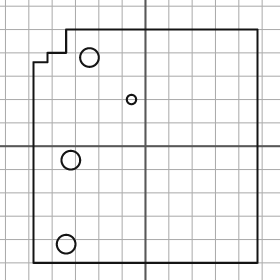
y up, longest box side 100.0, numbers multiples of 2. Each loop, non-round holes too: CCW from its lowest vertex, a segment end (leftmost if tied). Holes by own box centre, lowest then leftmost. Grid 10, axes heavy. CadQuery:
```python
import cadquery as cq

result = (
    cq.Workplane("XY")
    .moveTo(-48.0, -50.0)
    .lineTo(48.0, -50.0)
    .lineTo(48.0, 50.0)
    .lineTo(-34.0, 50.0)
    .lineTo(-34.0, 40.0)
    .lineTo(-42.0, 40.0)
    .lineTo(-42.0, 36.0)
    .lineTo(-48.0, 36.0)
    .close()
    .moveTo(-34.0, -42.0)
    .circle(4.0)
    .moveTo(-32.0, -6.0)
    .circle(4.0)
    .moveTo(-6.0, 20.0)
    .circle(2.0)
    .moveTo(-24.0, 38.0)
    .circle(4.0)
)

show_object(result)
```